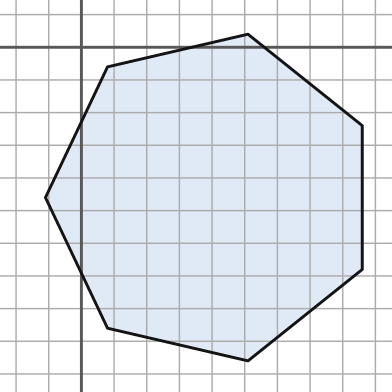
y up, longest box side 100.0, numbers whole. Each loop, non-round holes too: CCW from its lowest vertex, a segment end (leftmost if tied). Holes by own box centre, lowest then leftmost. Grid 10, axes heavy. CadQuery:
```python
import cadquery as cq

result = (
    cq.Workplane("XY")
    .moveTo(51.0, -96.0)
    .lineTo(86.0, -68.0)
    .lineTo(86.0, -24.0)
    .lineTo(51.0, 4.0)
    .lineTo(8.0, -6.0)
    .lineTo(-11.0, -46.0)
    .lineTo(8.0, -86.0)
    .close()
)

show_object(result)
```